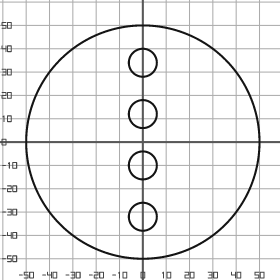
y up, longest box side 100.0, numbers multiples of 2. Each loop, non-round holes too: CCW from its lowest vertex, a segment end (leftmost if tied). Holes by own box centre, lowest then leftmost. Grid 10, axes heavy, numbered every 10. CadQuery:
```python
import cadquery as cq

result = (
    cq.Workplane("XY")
    .moveTo(0.0, 0.0)
    .circle(50.0)
    .moveTo(0.0, -32.0)
    .circle(6.0)
    .moveTo(0.0, -10.0)
    .circle(6.0)
    .moveTo(0.0, 12.0)
    .circle(6.0)
    .moveTo(0.0, 34.0)
    .circle(6.0)
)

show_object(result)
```